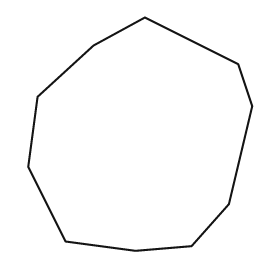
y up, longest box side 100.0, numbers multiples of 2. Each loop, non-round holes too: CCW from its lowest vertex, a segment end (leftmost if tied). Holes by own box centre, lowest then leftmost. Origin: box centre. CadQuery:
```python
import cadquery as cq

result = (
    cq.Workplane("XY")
    .moveTo(-2.0, -50.0)
    .lineTo(22.0, -48.0)
    .lineTo(38.0, -30.0)
    .lineTo(48.0, 12.0)
    .lineTo(42.0, 30.0)
    .lineTo(2.0, 50.0)
    .lineTo(-20.0, 38.0)
    .lineTo(-44.0, 16.0)
    .lineTo(-48.0, -14.0)
    .lineTo(-32.0, -46.0)
    .close()
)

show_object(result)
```